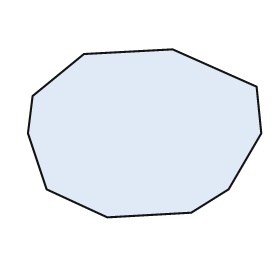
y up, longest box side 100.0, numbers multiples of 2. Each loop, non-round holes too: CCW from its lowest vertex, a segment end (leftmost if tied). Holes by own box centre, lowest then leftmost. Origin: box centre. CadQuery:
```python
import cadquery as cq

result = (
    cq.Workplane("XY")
    .moveTo(-16.0, -36.0)
    .lineTo(20.0, -34.0)
    .lineTo(36.0, -24.0)
    .lineTo(50.0, 0.0)
    .lineTo(48.0, 20.0)
    .lineTo(12.0, 36.0)
    .lineTo(-26.0, 34.0)
    .lineTo(-48.0, 16.0)
    .lineTo(-50.0, 0.0)
    .lineTo(-42.0, -24.0)
    .close()
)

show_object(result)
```